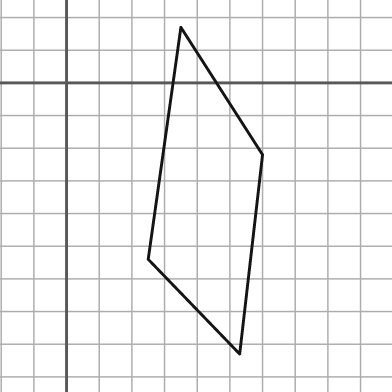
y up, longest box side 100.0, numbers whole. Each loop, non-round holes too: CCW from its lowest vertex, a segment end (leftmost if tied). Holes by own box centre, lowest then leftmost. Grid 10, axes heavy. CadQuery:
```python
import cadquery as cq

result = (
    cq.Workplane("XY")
    .moveTo(53.0, -83.0)
    .lineTo(60.0, -22.0)
    .lineTo(35.0, 17.0)
    .lineTo(25.0, -54.0)
    .close()
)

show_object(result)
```